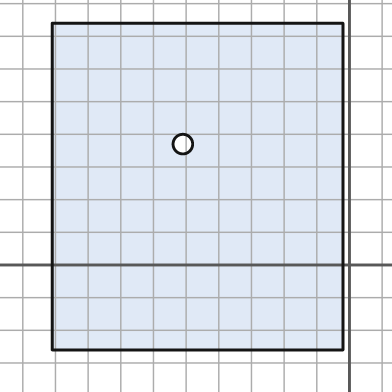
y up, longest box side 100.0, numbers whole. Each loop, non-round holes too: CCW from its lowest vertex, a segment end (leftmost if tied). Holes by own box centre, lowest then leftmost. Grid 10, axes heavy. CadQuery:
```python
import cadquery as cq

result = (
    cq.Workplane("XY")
    .moveTo(-91.0, -26.0)
    .lineTo(-2.0, -26.0)
    .lineTo(-2.0, 74.0)
    .lineTo(-91.0, 74.0)
    .close()
    .moveTo(-51.0, 37.0)
    .circle(3.0)
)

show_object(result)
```